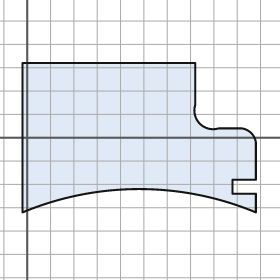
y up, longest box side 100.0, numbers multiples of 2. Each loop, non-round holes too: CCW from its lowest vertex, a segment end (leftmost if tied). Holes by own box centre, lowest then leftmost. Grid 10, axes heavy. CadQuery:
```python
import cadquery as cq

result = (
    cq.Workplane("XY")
    .moveTo(-2.0, -32.0)
    .threePointArc((48.0, -22.0), (98.0, -32.0))
    .lineTo(98.0, -24.0)
    .lineTo(88.0, -24.0)
    .lineTo(88.0, -18.0)
    .lineTo(98.0, -18.0)
    .lineTo(98.0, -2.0)
    .threePointArc((96.0, 2.0), (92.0, 4.0))
    .lineTo(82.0, 4.0)
    .threePointArc((74.0, 6.0), (72.0, 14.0))
    .lineTo(72.0, 32.0)
    .lineTo(-2.0, 32.0)
    .close()
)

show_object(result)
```